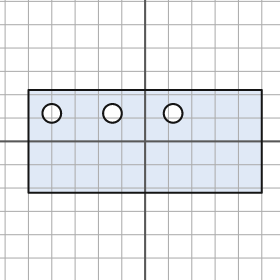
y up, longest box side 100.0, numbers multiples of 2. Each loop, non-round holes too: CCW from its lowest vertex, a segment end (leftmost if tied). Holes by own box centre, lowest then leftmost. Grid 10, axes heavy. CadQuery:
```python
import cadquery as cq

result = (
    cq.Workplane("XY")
    .moveTo(-50.0, -22.0)
    .lineTo(50.0, -22.0)
    .lineTo(50.0, 22.0)
    .lineTo(-50.0, 22.0)
    .close()
    .moveTo(-40.0, 12.0)
    .circle(4.0)
    .moveTo(-14.0, 12.0)
    .circle(4.0)
    .moveTo(12.0, 12.0)
    .circle(4.0)
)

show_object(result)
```